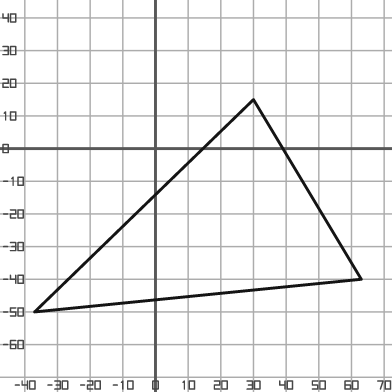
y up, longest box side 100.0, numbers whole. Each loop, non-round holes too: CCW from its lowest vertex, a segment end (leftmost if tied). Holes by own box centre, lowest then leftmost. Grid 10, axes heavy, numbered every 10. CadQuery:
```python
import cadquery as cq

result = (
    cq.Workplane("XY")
    .moveTo(-37.0, -50.0)
    .lineTo(63.0, -40.0)
    .lineTo(30.0, 15.0)
    .close()
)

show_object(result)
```